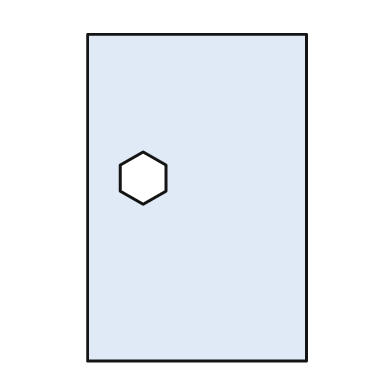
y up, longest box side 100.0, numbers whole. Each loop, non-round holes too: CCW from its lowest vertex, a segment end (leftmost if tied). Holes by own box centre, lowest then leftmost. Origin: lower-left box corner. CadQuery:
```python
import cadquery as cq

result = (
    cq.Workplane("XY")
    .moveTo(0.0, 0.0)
    .lineTo(67.0, 0.0)
    .lineTo(67.0, 100.0)
    .lineTo(0.0, 100.0)
    .close()
    .moveTo(17.0, 48.0)
    .lineTo(24.0, 52.0)
    .lineTo(24.0, 60.0)
    .lineTo(17.0, 64.0)
    .lineTo(10.0, 60.0)
    .lineTo(10.0, 52.0)
    .close()
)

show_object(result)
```